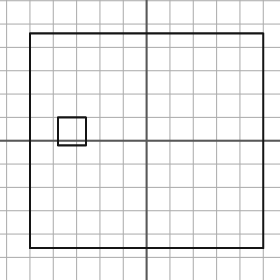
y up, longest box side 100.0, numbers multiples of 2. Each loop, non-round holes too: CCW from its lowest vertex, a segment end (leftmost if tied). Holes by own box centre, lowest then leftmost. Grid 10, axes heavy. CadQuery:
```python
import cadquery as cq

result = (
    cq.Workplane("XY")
    .moveTo(-50.0, -46.0)
    .lineTo(50.0, -46.0)
    .lineTo(50.0, 46.0)
    .lineTo(-50.0, 46.0)
    .close()
    .moveTo(-38.0, -2.0)
    .lineTo(-26.0, -2.0)
    .lineTo(-26.0, 10.0)
    .lineTo(-38.0, 10.0)
    .close()
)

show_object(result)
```